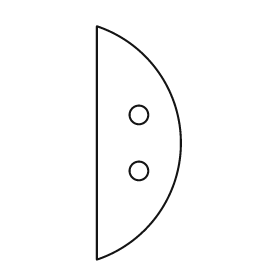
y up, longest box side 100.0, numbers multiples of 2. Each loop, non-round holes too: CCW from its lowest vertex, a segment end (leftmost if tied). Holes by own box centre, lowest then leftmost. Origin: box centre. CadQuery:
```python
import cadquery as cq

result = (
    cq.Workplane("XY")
    .moveTo(-18.0, -50.0)
    .threePointArc((18.0, 0.0), (-18.0, 50.0))
    .close()
    .moveTo(0.0, -12.0)
    .circle(4.0)
    .moveTo(0.0, 12.0)
    .circle(4.0)
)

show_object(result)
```